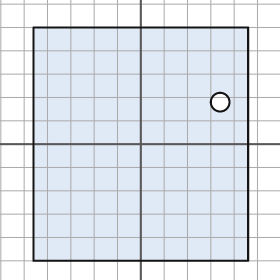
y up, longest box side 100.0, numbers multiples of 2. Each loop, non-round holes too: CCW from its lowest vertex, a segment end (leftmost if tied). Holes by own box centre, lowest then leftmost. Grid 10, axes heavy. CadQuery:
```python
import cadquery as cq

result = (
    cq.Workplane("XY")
    .moveTo(-46.0, -50.0)
    .lineTo(46.0, -50.0)
    .lineTo(46.0, 50.0)
    .lineTo(-46.0, 50.0)
    .close()
    .moveTo(34.0, 18.0)
    .circle(4.0)
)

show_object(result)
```